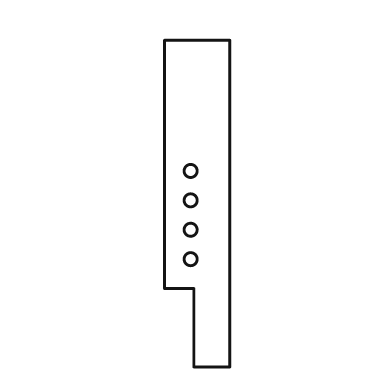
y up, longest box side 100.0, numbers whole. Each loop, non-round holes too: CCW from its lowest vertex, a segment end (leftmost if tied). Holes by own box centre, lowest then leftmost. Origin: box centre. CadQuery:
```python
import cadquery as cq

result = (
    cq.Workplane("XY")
    .moveTo(-1.0, -50.0)
    .lineTo(10.0, -50.0)
    .lineTo(10.0, 50.0)
    .lineTo(-10.0, 50.0)
    .lineTo(-10.0, -26.0)
    .lineTo(-1.0, -26.0)
    .close()
    .moveTo(-2.0, -17.0)
    .circle(2.0)
    .moveTo(-2.0, -8.0)
    .circle(2.0)
    .moveTo(-2.0, 1.0)
    .circle(2.0)
    .moveTo(-2.0, 10.0)
    .circle(2.0)
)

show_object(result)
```